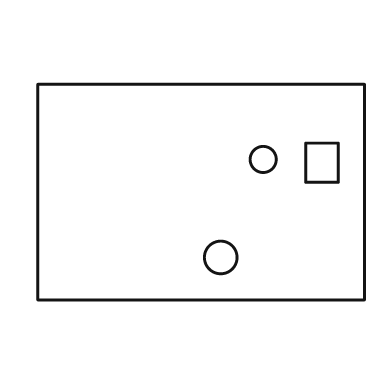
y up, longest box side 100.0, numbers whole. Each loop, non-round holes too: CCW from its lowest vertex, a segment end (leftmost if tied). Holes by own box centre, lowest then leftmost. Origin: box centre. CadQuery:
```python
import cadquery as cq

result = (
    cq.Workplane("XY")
    .moveTo(-50.0, -33.0)
    .lineTo(50.0, -33.0)
    .lineTo(50.0, 33.0)
    .lineTo(-50.0, 33.0)
    .close()
    .moveTo(6.0, -20.0)
    .circle(5.0)
    .moveTo(32.0, 3.0)
    .lineTo(42.0, 3.0)
    .lineTo(42.0, 15.0)
    .lineTo(32.0, 15.0)
    .close()
    .moveTo(19.0, 10.0)
    .circle(4.0)
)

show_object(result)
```